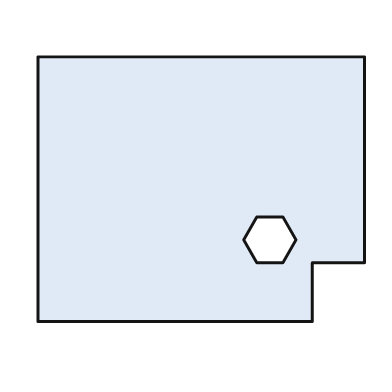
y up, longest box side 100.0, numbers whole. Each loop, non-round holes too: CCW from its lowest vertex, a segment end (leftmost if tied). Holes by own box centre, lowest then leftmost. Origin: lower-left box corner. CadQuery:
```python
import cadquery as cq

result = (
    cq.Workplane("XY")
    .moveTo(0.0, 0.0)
    .lineTo(84.0, 0.0)
    .lineTo(84.0, 18.0)
    .lineTo(100.0, 18.0)
    .lineTo(100.0, 81.0)
    .lineTo(0.0, 81.0)
    .close()
    .moveTo(67.0, 18.0)
    .lineTo(75.0, 18.0)
    .lineTo(79.0, 25.0)
    .lineTo(75.0, 32.0)
    .lineTo(67.0, 32.0)
    .lineTo(63.0, 25.0)
    .close()
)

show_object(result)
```